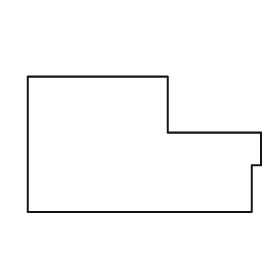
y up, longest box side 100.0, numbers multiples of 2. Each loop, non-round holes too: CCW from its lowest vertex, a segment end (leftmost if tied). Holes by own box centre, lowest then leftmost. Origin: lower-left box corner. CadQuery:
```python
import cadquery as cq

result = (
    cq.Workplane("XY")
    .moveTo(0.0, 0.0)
    .lineTo(96.0, 0.0)
    .lineTo(96.0, 20.0)
    .lineTo(100.0, 20.0)
    .lineTo(100.0, 34.0)
    .lineTo(60.0, 34.0)
    .lineTo(60.0, 58.0)
    .lineTo(0.0, 58.0)
    .close()
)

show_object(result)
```